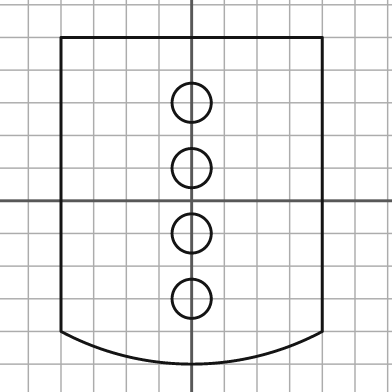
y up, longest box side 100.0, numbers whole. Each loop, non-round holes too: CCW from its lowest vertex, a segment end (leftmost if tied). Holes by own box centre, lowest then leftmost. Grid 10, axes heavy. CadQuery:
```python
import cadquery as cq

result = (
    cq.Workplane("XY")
    .moveTo(-40.0, -40.0)
    .threePointArc((0.0, -50.0), (40.0, -40.0))
    .lineTo(40.0, 50.0)
    .lineTo(-40.0, 50.0)
    .close()
    .moveTo(0.0, -30.0)
    .circle(6.0)
    .moveTo(0.0, -10.0)
    .circle(6.0)
    .moveTo(0.0, 10.0)
    .circle(6.0)
    .moveTo(0.0, 30.0)
    .circle(6.0)
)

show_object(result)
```